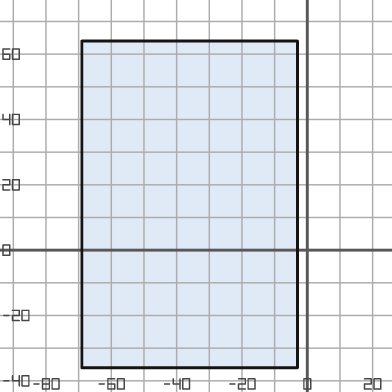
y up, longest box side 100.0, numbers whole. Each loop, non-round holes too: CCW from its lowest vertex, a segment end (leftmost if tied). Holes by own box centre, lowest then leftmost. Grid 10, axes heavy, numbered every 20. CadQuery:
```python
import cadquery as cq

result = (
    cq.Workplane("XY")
    .moveTo(-69.0, -36.0)
    .lineTo(-3.0, -36.0)
    .lineTo(-3.0, 64.0)
    .lineTo(-69.0, 64.0)
    .close()
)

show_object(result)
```